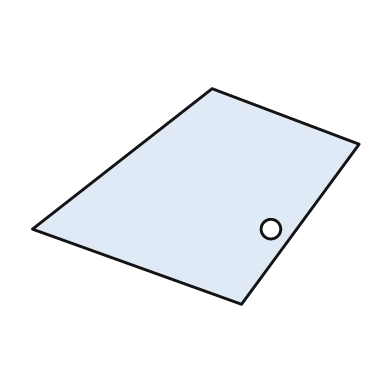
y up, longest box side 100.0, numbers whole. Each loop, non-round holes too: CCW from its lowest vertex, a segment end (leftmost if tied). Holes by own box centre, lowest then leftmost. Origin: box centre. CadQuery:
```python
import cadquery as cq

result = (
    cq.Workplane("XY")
    .moveTo(14.0, -33.0)
    .lineTo(50.0, 16.0)
    .lineTo(5.0, 33.0)
    .lineTo(-50.0, -10.0)
    .close()
    .moveTo(23.0, -10.0)
    .circle(3.0)
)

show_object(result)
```